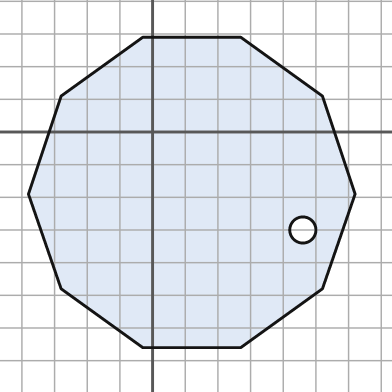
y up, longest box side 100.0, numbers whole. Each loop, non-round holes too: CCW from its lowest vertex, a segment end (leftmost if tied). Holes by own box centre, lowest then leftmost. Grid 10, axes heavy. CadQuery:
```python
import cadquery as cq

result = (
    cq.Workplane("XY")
    .moveTo(-3.0, -66.0)
    .lineTo(27.0, -66.0)
    .lineTo(52.0, -48.0)
    .lineTo(62.0, -19.0)
    .lineTo(52.0, 11.0)
    .lineTo(27.0, 29.0)
    .lineTo(-3.0, 29.0)
    .lineTo(-28.0, 11.0)
    .lineTo(-38.0, -19.0)
    .lineTo(-28.0, -48.0)
    .close()
    .moveTo(46.0, -30.0)
    .circle(4.0)
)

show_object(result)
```